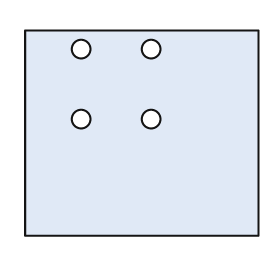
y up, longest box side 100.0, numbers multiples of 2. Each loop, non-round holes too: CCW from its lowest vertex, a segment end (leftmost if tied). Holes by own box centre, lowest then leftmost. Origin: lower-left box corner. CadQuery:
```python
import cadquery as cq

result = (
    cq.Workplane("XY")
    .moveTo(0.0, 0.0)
    .lineTo(100.0, 0.0)
    .lineTo(100.0, 88.0)
    .lineTo(0.0, 88.0)
    .close()
    .moveTo(24.0, 50.0)
    .circle(4.0)
    .moveTo(54.0, 50.0)
    .circle(4.0)
    .moveTo(24.0, 80.0)
    .circle(4.0)
    .moveTo(54.0, 80.0)
    .circle(4.0)
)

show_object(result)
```